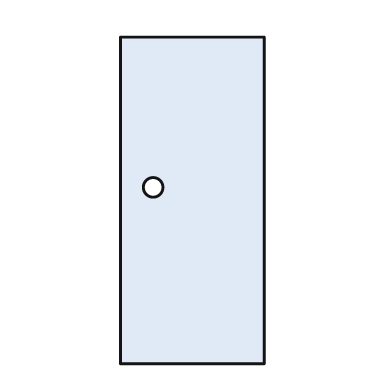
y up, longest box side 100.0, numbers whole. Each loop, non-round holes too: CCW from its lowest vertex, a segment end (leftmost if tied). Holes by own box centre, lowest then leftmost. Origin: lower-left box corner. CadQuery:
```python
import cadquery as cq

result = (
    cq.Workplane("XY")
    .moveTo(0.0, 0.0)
    .lineTo(44.0, 0.0)
    .lineTo(44.0, 100.0)
    .lineTo(0.0, 100.0)
    .close()
    .moveTo(10.0, 54.0)
    .circle(3.0)
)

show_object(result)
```